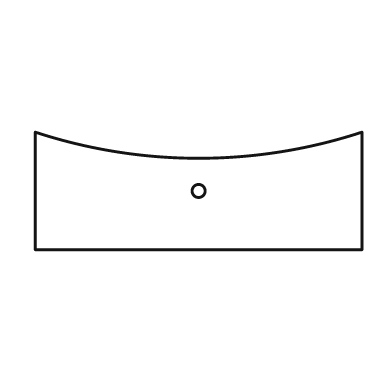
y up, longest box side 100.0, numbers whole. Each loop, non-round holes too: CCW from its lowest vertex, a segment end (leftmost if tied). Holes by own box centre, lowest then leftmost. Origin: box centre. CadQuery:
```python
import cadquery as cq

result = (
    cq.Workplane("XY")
    .moveTo(-50.0, -18.0)
    .lineTo(50.0, -18.0)
    .lineTo(50.0, 18.0)
    .threePointArc((0.0, 10.0), (-50.0, 18.0))
    .close()
    .moveTo(0.0, 0.0)
    .circle(2.0)
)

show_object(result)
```